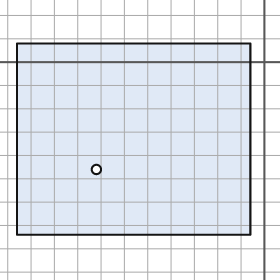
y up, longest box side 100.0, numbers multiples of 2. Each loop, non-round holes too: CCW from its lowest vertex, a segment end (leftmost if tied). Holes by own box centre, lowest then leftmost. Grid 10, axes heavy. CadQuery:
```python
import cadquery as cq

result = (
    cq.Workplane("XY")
    .moveTo(-106.0, -74.0)
    .lineTo(-6.0, -74.0)
    .lineTo(-6.0, 8.0)
    .lineTo(-106.0, 8.0)
    .close()
    .moveTo(-72.0, -46.0)
    .circle(2.0)
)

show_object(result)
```